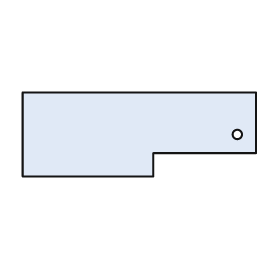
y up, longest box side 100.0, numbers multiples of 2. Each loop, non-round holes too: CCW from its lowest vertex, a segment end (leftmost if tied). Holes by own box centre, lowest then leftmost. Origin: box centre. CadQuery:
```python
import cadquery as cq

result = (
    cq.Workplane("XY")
    .moveTo(-50.0, -18.0)
    .lineTo(6.0, -18.0)
    .lineTo(6.0, -8.0)
    .lineTo(50.0, -8.0)
    .lineTo(50.0, 18.0)
    .lineTo(-50.0, 18.0)
    .close()
    .moveTo(42.0, 0.0)
    .circle(2.0)
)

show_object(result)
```